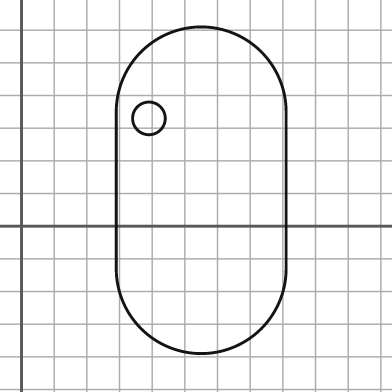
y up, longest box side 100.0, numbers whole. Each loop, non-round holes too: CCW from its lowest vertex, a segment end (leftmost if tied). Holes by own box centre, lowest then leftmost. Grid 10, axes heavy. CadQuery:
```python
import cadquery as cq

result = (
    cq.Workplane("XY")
    .moveTo(29.0, -13.0)
    .threePointArc((55.0, -39.0), (81.0, -13.0))
    .lineTo(81.0, 35.0)
    .threePointArc((55.0, 61.0), (29.0, 35.0))
    .close()
    .moveTo(39.0, 33.0)
    .circle(5.0)
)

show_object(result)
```